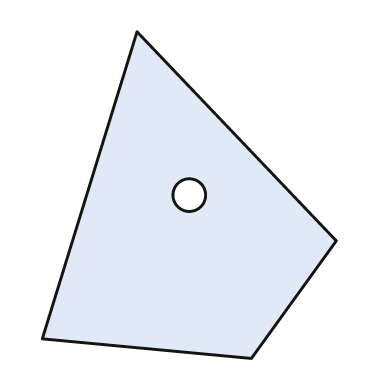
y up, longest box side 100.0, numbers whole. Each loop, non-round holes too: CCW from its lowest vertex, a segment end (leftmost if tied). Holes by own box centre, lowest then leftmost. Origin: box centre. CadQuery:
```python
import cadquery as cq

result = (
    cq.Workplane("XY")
    .moveTo(19.0, -50.0)
    .lineTo(45.0, -14.0)
    .lineTo(-16.0, 50.0)
    .lineTo(-45.0, -44.0)
    .close()
    .moveTo(0.0, 0.0)
    .circle(5.0)
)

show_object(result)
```